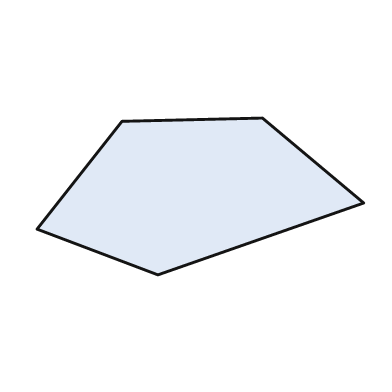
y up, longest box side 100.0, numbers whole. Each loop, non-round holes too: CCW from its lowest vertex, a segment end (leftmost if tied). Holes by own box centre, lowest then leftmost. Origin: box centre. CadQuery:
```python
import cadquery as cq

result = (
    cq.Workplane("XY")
    .moveTo(-13.0, -24.0)
    .lineTo(50.0, -2.0)
    .lineTo(19.0, 24.0)
    .lineTo(-24.0, 23.0)
    .lineTo(-50.0, -10.0)
    .close()
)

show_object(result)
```